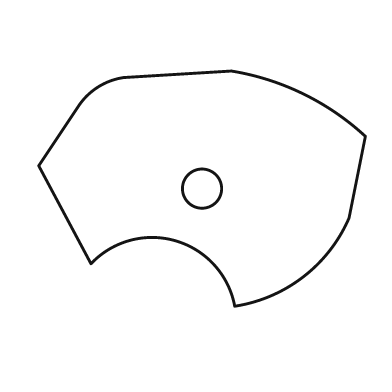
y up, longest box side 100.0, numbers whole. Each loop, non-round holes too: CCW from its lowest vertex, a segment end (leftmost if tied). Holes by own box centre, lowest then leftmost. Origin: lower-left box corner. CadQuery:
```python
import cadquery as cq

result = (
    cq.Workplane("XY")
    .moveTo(60.0, 0.0)
    .threePointArc((81.0, 9.0), (95.0, 27.0))
    .lineTo(100.0, 52.0)
    .threePointArc((81.0, 65.0), (59.0, 72.0))
    .lineTo(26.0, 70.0)
    .threePointArc((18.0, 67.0), (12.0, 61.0))
    .lineTo(0.0, 43.0)
    .lineTo(16.0, 13.0)
    .threePointArc((42.0, 20.0), (60.0, 0.0))
    .close()
    .moveTo(50.0, 36.0)
    .circle(6.0)
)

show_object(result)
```